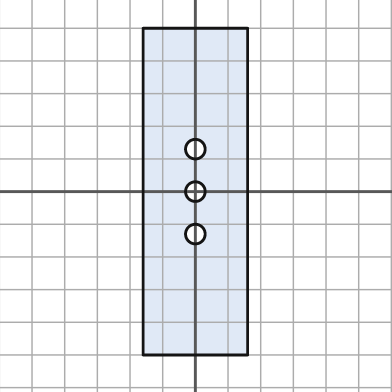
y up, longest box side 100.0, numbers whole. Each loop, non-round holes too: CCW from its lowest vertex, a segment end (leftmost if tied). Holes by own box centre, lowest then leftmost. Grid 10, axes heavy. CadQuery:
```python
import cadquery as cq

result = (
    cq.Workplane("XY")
    .moveTo(-16.0, -50.0)
    .lineTo(16.0, -50.0)
    .lineTo(16.0, 50.0)
    .lineTo(-16.0, 50.0)
    .close()
    .moveTo(0.0, -13.0)
    .circle(3.0)
    .moveTo(0.0, 0.0)
    .circle(3.0)
    .moveTo(0.0, 13.0)
    .circle(3.0)
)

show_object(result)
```